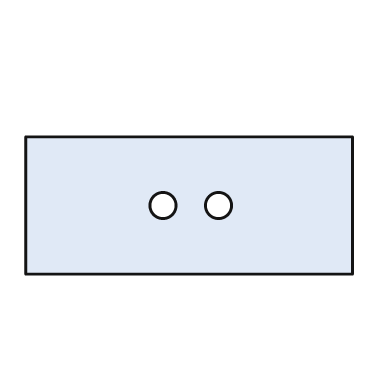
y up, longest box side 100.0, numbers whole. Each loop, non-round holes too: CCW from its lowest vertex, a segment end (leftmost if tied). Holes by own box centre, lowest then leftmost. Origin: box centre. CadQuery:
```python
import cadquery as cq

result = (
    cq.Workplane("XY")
    .moveTo(-50.0, -21.0)
    .lineTo(50.0, -21.0)
    .lineTo(50.0, 21.0)
    .lineTo(-50.0, 21.0)
    .close()
    .moveTo(-8.0, 0.0)
    .circle(4.0)
    .moveTo(9.0, 0.0)
    .circle(4.0)
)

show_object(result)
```